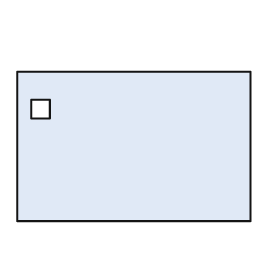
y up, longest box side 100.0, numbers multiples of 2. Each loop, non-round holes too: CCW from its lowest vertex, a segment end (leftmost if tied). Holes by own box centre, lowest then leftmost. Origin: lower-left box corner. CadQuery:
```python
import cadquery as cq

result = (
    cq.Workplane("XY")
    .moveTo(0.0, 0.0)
    .lineTo(100.0, 0.0)
    .lineTo(100.0, 64.0)
    .lineTo(0.0, 64.0)
    .close()
    .moveTo(6.0, 44.0)
    .lineTo(14.0, 44.0)
    .lineTo(14.0, 52.0)
    .lineTo(6.0, 52.0)
    .close()
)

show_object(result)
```